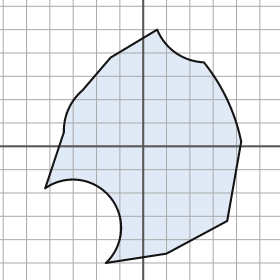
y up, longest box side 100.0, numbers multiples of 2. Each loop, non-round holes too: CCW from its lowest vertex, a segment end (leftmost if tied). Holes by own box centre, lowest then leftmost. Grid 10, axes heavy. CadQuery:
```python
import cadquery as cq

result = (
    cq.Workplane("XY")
    .moveTo(-16.0, -50.0)
    .lineTo(10.0, -46.0)
    .lineTo(36.0, -32.0)
    .lineTo(42.0, 2.0)
    .threePointArc((36.0, 20.0), (26.0, 36.0))
    .threePointArc((14.0, 40.0), (6.0, 50.0))
    .lineTo(-14.0, 38.0)
    .lineTo(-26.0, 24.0)
    .threePointArc((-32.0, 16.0), (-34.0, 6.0))
    .lineTo(-42.0, -18.0)
    .threePointArc((-14.0, -22.0), (-16.0, -50.0))
    .close()
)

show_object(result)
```